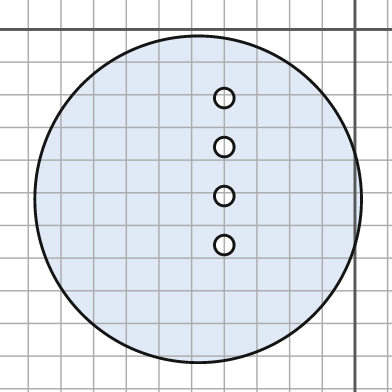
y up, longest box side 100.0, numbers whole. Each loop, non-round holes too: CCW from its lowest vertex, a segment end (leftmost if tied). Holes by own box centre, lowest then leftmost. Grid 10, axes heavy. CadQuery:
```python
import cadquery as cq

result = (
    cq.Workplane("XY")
    .moveTo(-48.0, -52.0)
    .circle(50.0)
    .moveTo(-40.0, -66.0)
    .circle(3.0)
    .moveTo(-40.0, -51.0)
    .circle(3.0)
    .moveTo(-40.0, -36.0)
    .circle(3.0)
    .moveTo(-40.0, -21.0)
    .circle(3.0)
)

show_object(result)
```